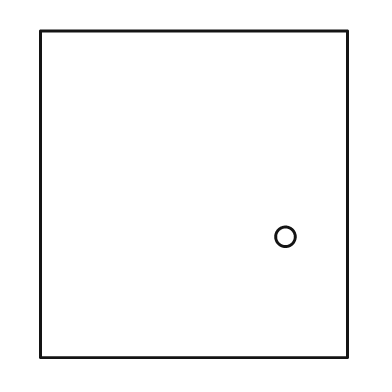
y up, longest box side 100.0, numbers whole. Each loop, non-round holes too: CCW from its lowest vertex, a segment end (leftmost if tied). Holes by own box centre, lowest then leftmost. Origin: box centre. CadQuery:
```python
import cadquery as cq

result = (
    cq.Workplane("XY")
    .moveTo(-47.0, -50.0)
    .lineTo(47.0, -50.0)
    .lineTo(47.0, 50.0)
    .lineTo(-47.0, 50.0)
    .close()
    .moveTo(28.0, -13.0)
    .circle(3.0)
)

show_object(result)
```